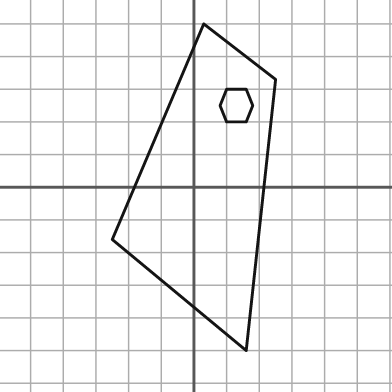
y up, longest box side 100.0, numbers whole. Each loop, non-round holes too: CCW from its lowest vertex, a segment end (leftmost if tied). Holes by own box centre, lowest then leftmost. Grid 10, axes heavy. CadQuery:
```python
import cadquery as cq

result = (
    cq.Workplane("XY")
    .moveTo(16.0, -50.0)
    .lineTo(25.0, 33.0)
    .lineTo(3.0, 50.0)
    .lineTo(-25.0, -16.0)
    .close()
    .moveTo(10.0, 20.0)
    .lineTo(16.0, 20.0)
    .lineTo(18.0, 25.0)
    .lineTo(16.0, 30.0)
    .lineTo(10.0, 30.0)
    .lineTo(8.0, 25.0)
    .close()
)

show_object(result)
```